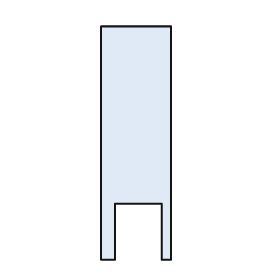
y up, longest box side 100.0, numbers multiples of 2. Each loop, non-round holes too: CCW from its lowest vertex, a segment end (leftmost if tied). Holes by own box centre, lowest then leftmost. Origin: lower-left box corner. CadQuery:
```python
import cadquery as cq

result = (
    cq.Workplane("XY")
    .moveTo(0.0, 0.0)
    .lineTo(6.0, 0.0)
    .lineTo(6.0, 24.0)
    .lineTo(26.0, 24.0)
    .lineTo(26.0, 0.0)
    .lineTo(30.0, 0.0)
    .lineTo(30.0, 100.0)
    .lineTo(0.0, 100.0)
    .close()
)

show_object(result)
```